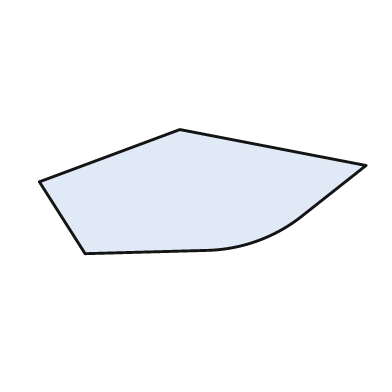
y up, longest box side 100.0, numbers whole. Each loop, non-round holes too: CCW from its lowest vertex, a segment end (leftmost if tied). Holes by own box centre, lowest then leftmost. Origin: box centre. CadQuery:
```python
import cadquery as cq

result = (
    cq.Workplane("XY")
    .moveTo(-36.0, -19.0)
    .lineTo(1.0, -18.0)
    .threePointArc((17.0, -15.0), (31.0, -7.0))
    .lineTo(50.0, 8.0)
    .lineTo(-7.0, 19.0)
    .lineTo(-50.0, 3.0)
    .close()
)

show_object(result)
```